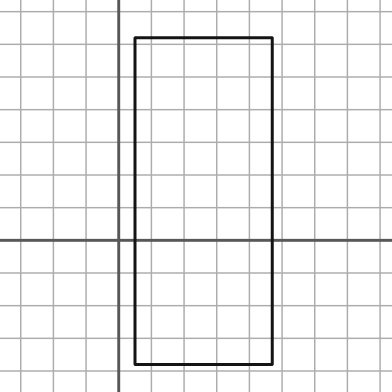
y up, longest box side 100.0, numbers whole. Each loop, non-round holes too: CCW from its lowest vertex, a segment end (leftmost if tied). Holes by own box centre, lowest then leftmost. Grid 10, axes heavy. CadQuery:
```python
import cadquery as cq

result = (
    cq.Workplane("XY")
    .moveTo(5.0, -38.0)
    .lineTo(47.0, -38.0)
    .lineTo(47.0, 62.0)
    .lineTo(5.0, 62.0)
    .close()
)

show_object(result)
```